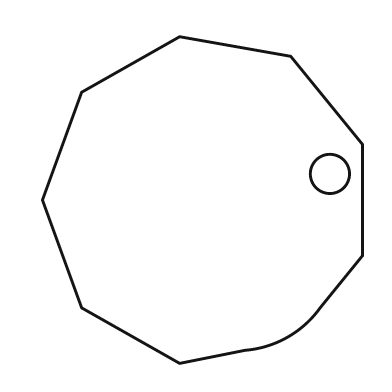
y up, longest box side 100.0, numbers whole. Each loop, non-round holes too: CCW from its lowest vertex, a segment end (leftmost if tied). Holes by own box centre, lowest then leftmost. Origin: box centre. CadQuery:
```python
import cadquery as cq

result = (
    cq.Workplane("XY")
    .moveTo(-7.0, -50.0)
    .lineTo(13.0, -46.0)
    .threePointArc((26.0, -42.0), (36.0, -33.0))
    .lineTo(49.0, -17.0)
    .lineTo(49.0, 17.0)
    .lineTo(27.0, 44.0)
    .lineTo(-7.0, 50.0)
    .lineTo(-37.0, 33.0)
    .lineTo(-49.0, 0.0)
    .lineTo(-37.0, -33.0)
    .close()
    .moveTo(39.0, 8.0)
    .circle(6.0)
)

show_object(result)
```